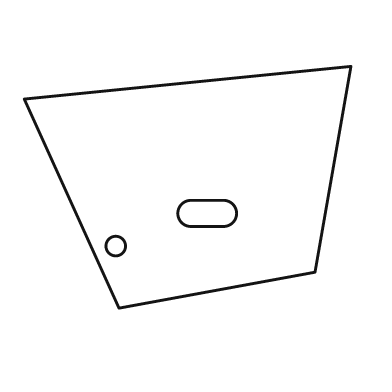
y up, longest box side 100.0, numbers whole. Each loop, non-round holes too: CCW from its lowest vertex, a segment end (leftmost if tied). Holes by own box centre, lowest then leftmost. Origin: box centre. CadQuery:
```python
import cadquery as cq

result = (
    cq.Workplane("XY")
    .moveTo(-21.0, -37.0)
    .lineTo(39.0, -26.0)
    .lineTo(50.0, 37.0)
    .lineTo(-50.0, 27.0)
    .close()
    .moveTo(-22.0, -18.0)
    .circle(3.0)
    .moveTo(1.0, -12.0)
    .lineTo(11.0, -12.0)
    .threePointArc((15.0, -8.0), (11.0, -4.0))
    .lineTo(1.0, -4.0)
    .threePointArc((-3.0, -8.0), (1.0, -12.0))
    .close()
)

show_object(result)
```